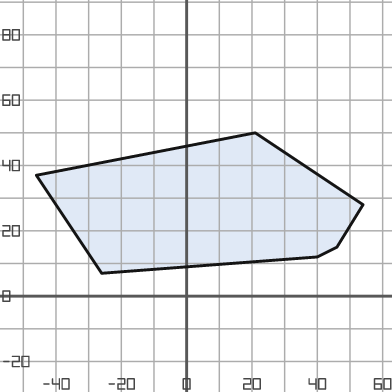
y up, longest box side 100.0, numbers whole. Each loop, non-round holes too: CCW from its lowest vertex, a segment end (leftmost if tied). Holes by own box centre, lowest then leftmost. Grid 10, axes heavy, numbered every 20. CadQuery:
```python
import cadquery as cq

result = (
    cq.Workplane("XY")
    .moveTo(-26.0, 7.0)
    .lineTo(40.0, 12.0)
    .lineTo(46.0, 15.0)
    .lineTo(54.0, 28.0)
    .lineTo(21.0, 50.0)
    .lineTo(-46.0, 37.0)
    .close()
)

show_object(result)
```